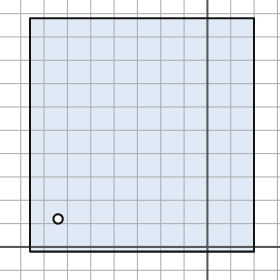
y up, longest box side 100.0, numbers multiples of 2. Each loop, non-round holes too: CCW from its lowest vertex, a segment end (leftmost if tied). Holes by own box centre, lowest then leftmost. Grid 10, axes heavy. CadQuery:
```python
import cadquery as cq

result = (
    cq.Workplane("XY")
    .moveTo(-76.0, -2.0)
    .lineTo(20.0, -2.0)
    .lineTo(20.0, 98.0)
    .lineTo(-76.0, 98.0)
    .close()
    .moveTo(-64.0, 12.0)
    .circle(2.0)
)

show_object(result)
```